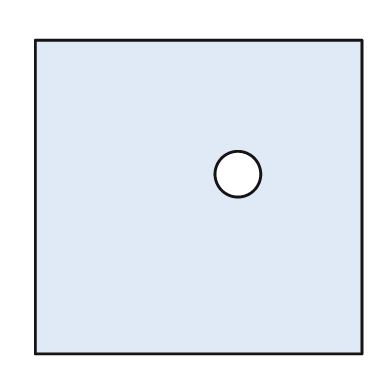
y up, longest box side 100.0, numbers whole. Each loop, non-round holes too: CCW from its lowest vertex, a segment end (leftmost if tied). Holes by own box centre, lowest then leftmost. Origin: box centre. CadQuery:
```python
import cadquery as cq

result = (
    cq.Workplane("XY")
    .moveTo(-50.0, -48.0)
    .lineTo(50.0, -48.0)
    .lineTo(50.0, 48.0)
    .lineTo(-50.0, 48.0)
    .close()
    .moveTo(12.0, 7.0)
    .circle(7.0)
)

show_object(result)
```